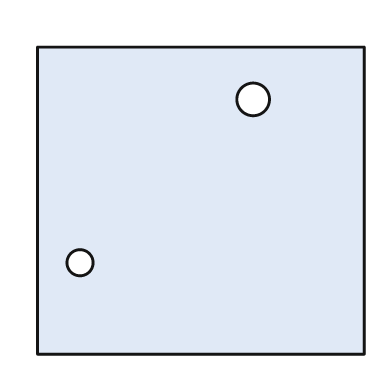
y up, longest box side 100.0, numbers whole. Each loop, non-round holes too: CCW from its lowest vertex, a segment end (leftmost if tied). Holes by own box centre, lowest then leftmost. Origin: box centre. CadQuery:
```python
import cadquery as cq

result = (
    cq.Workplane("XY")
    .moveTo(-50.0, -47.0)
    .lineTo(50.0, -47.0)
    .lineTo(50.0, 47.0)
    .lineTo(-50.0, 47.0)
    .close()
    .moveTo(-37.0, -19.0)
    .circle(4.0)
    .moveTo(16.0, 31.0)
    .circle(5.0)
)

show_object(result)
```